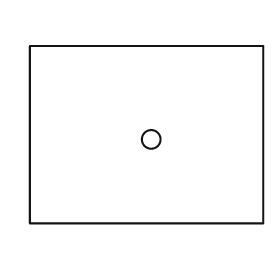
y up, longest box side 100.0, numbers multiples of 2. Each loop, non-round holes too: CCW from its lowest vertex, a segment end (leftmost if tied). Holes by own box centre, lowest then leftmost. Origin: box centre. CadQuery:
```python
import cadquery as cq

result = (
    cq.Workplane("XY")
    .moveTo(-50.0, -38.0)
    .lineTo(50.0, -38.0)
    .lineTo(50.0, 38.0)
    .lineTo(-50.0, 38.0)
    .close()
    .moveTo(2.0, -2.0)
    .circle(4.0)
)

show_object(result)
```